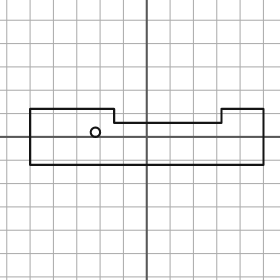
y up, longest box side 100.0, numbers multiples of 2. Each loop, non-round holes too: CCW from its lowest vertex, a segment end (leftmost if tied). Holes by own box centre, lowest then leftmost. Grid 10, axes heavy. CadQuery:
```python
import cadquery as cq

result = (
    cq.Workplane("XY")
    .moveTo(-50.0, -12.0)
    .lineTo(50.0, -12.0)
    .lineTo(50.0, 12.0)
    .lineTo(32.0, 12.0)
    .lineTo(32.0, 6.0)
    .lineTo(-14.0, 6.0)
    .lineTo(-14.0, 12.0)
    .lineTo(-50.0, 12.0)
    .close()
    .moveTo(-22.0, 2.0)
    .circle(2.0)
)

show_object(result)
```